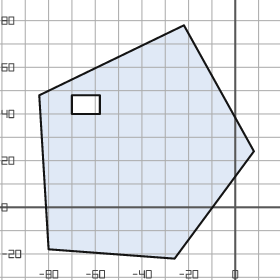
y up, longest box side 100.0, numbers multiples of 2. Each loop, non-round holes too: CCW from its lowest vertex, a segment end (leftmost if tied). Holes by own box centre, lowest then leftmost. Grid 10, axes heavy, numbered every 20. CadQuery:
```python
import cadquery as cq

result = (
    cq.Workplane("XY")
    .moveTo(-26.0, -22.0)
    .lineTo(8.0, 24.0)
    .lineTo(-22.0, 78.0)
    .lineTo(-84.0, 48.0)
    .lineTo(-80.0, -18.0)
    .close()
    .moveTo(-70.0, 40.0)
    .lineTo(-58.0, 40.0)
    .lineTo(-58.0, 48.0)
    .lineTo(-70.0, 48.0)
    .close()
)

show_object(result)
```